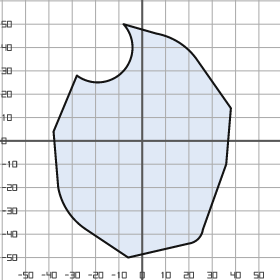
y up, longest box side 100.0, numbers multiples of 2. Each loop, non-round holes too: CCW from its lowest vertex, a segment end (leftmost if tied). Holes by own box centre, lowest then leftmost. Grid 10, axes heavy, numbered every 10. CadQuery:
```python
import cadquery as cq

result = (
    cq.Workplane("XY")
    .moveTo(-6.0, -50.0)
    .lineTo(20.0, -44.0)
    .threePointArc((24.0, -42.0), (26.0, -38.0))
    .lineTo(36.0, -10.0)
    .lineTo(38.0, 14.0)
    .lineTo(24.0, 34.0)
    .threePointArc((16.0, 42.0), (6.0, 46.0))
    .lineTo(-8.0, 50.0)
    .threePointArc((-8.0, 30.0), (-28.0, 28.0))
    .lineTo(-38.0, 4.0)
    .lineTo(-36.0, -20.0)
    .threePointArc((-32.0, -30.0), (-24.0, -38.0))
    .close()
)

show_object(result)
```